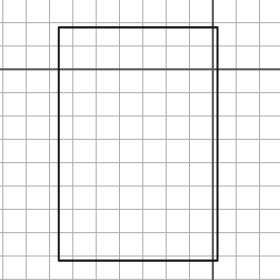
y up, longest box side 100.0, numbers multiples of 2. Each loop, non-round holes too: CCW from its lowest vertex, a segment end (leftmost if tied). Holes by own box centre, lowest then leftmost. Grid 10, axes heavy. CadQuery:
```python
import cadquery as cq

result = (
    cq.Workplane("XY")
    .moveTo(-66.0, -82.0)
    .lineTo(2.0, -82.0)
    .lineTo(2.0, 18.0)
    .lineTo(-66.0, 18.0)
    .close()
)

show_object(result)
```